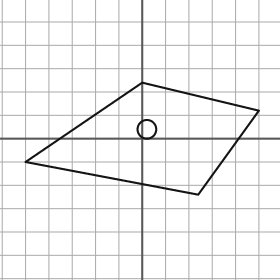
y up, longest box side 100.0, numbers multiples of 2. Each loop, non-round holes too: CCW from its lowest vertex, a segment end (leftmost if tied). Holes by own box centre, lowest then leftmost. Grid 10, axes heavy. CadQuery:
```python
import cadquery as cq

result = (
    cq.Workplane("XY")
    .moveTo(24.0, -24.0)
    .lineTo(50.0, 12.0)
    .lineTo(0.0, 24.0)
    .lineTo(-50.0, -10.0)
    .close()
    .moveTo(2.0, 4.0)
    .circle(4.0)
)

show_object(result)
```